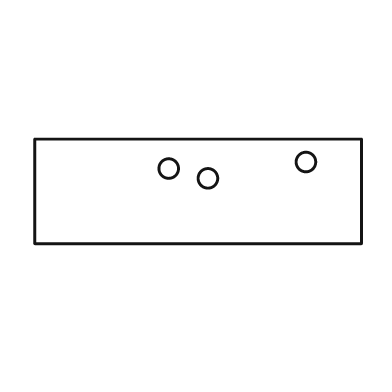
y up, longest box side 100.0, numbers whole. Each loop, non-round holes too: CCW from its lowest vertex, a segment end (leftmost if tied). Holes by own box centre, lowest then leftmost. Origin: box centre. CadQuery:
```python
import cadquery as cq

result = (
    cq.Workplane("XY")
    .moveTo(-50.0, -16.0)
    .lineTo(50.0, -16.0)
    .lineTo(50.0, 16.0)
    .lineTo(-50.0, 16.0)
    .close()
    .moveTo(3.0, 4.0)
    .circle(3.0)
    .moveTo(-9.0, 7.0)
    .circle(3.0)
    .moveTo(33.0, 9.0)
    .circle(3.0)
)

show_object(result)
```